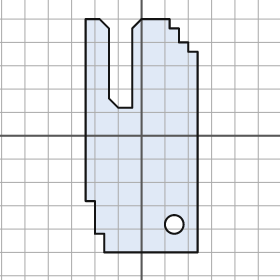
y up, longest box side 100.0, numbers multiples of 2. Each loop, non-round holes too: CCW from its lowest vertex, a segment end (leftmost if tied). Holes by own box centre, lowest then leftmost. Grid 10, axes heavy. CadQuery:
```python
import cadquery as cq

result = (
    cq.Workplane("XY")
    .moveTo(-16.0, -50.0)
    .lineTo(24.0, -50.0)
    .lineTo(24.0, 36.0)
    .lineTo(20.0, 36.0)
    .lineTo(20.0, 40.0)
    .lineTo(16.0, 40.0)
    .lineTo(16.0, 46.0)
    .lineTo(12.0, 46.0)
    .lineTo(12.0, 50.0)
    .lineTo(0.0, 50.0)
    .lineTo(-4.0, 46.0)
    .lineTo(-4.0, 12.0)
    .lineTo(-10.0, 12.0)
    .lineTo(-14.0, 16.0)
    .lineTo(-14.0, 46.0)
    .lineTo(-18.0, 50.0)
    .lineTo(-24.0, 50.0)
    .lineTo(-24.0, -28.0)
    .lineTo(-20.0, -28.0)
    .lineTo(-20.0, -42.0)
    .lineTo(-16.0, -42.0)
    .close()
    .moveTo(14.0, -38.0)
    .circle(4.0)
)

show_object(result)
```